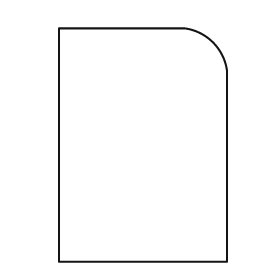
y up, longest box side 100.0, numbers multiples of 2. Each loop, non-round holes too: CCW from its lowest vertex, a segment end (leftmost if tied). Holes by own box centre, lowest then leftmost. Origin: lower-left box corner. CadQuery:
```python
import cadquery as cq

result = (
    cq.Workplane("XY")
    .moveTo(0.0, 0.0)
    .lineTo(72.0, 0.0)
    .lineTo(72.0, 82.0)
    .threePointArc((66.0, 94.0), (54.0, 100.0))
    .lineTo(0.0, 100.0)
    .close()
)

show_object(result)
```